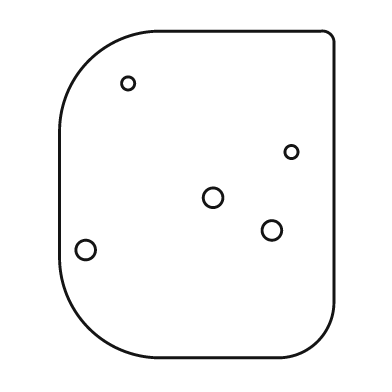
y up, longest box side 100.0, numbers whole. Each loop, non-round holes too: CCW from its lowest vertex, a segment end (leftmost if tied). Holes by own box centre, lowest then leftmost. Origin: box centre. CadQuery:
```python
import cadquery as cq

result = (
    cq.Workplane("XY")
    .moveTo(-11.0, -50.0)
    .lineTo(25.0, -50.0)
    .threePointArc((37.0, -45.0), (42.0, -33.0))
    .lineTo(42.0, 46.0)
    .threePointArc((41.0, 49.0), (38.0, 50.0))
    .lineTo(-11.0, 50.0)
    .threePointArc((-33.0, 41.0), (-42.0, 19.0))
    .lineTo(-42.0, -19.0)
    .threePointArc((-33.0, -41.0), (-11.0, -50.0))
    .close()
    .moveTo(-34.0, -17.0)
    .circle(3.0)
    .moveTo(23.0, -11.0)
    .circle(3.0)
    .moveTo(5.0, -1.0)
    .circle(3.0)
    .moveTo(29.0, 13.0)
    .circle(2.0)
    .moveTo(-21.0, 34.0)
    .circle(2.0)
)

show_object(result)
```